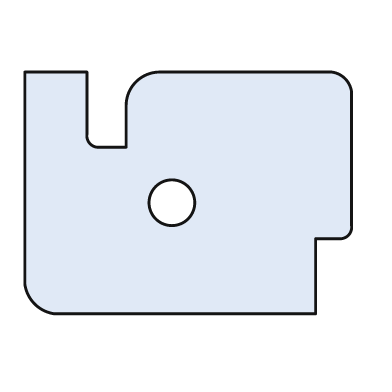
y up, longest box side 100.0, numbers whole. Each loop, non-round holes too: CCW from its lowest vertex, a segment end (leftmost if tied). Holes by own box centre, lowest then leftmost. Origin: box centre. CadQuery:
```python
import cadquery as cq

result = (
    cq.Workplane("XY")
    .moveTo(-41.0, -37.0)
    .lineTo(39.0, -37.0)
    .lineTo(39.0, -14.0)
    .lineTo(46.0, -14.0)
    .threePointArc((49.0, -13.0), (50.0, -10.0))
    .lineTo(50.0, 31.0)
    .threePointArc((48.0, 35.0), (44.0, 37.0))
    .lineTo(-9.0, 37.0)
    .threePointArc((-16.0, 34.0), (-19.0, 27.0))
    .lineTo(-19.0, 14.0)
    .lineTo(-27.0, 14.0)
    .threePointArc((-30.0, 15.0), (-31.0, 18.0))
    .lineTo(-31.0, 37.0)
    .lineTo(-50.0, 37.0)
    .lineTo(-50.0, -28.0)
    .threePointArc((-47.0, -34.0), (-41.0, -37.0))
    .close()
    .moveTo(-5.0, -3.0)
    .circle(7.0)
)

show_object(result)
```